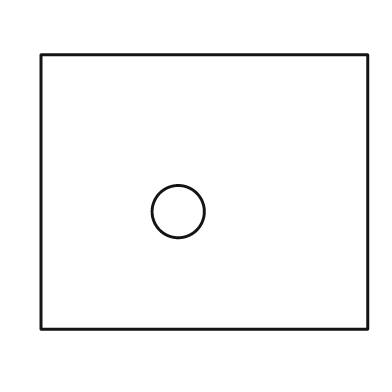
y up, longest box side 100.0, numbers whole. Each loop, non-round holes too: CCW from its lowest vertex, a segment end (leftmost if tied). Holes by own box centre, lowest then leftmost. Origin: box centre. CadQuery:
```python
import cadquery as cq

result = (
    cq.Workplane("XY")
    .moveTo(-50.0, -42.0)
    .lineTo(50.0, -42.0)
    .lineTo(50.0, 42.0)
    .lineTo(-50.0, 42.0)
    .close()
    .moveTo(-8.0, -6.0)
    .circle(8.0)
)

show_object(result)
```